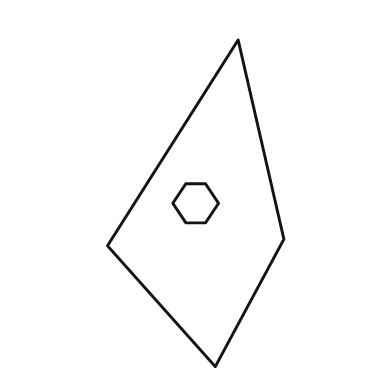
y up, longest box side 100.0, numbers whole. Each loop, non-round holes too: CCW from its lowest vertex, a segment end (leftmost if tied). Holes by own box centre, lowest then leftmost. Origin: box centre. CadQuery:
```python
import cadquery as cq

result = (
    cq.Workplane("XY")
    .moveTo(6.0, -50.0)
    .lineTo(27.0, -11.0)
    .lineTo(13.0, 50.0)
    .lineTo(-27.0, -13.0)
    .close()
    .moveTo(-3.0, -6.0)
    .lineTo(3.0, -6.0)
    .lineTo(7.0, 0.0)
    .lineTo(3.0, 6.0)
    .lineTo(-3.0, 6.0)
    .lineTo(-7.0, 0.0)
    .close()
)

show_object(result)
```